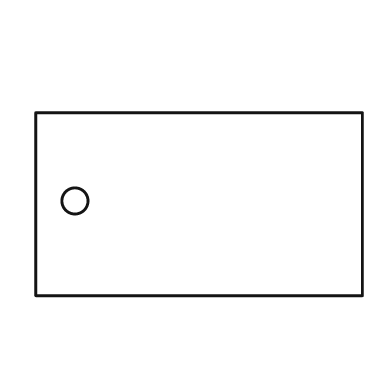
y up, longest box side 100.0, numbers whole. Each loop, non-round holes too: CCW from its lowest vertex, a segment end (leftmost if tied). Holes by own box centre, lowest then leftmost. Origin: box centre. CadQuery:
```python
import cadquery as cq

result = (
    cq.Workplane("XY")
    .moveTo(-50.0, -28.0)
    .lineTo(50.0, -28.0)
    .lineTo(50.0, 28.0)
    .lineTo(-50.0, 28.0)
    .close()
    .moveTo(-38.0, 1.0)
    .circle(4.0)
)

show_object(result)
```